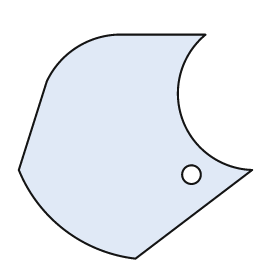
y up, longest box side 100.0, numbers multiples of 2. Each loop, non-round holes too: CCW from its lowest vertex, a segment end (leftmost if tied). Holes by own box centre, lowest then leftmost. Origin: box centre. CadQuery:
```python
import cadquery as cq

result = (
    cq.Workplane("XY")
    .moveTo(0.0, -48.0)
    .lineTo(50.0, -10.0)
    .threePointArc((20.0, 12.0), (30.0, 48.0))
    .lineTo(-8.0, 48.0)
    .threePointArc((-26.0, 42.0), (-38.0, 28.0))
    .lineTo(-50.0, -10.0)
    .threePointArc((-30.0, -36.0), (0.0, -48.0))
    .close()
    .moveTo(24.0, -12.0)
    .circle(4.0)
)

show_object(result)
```